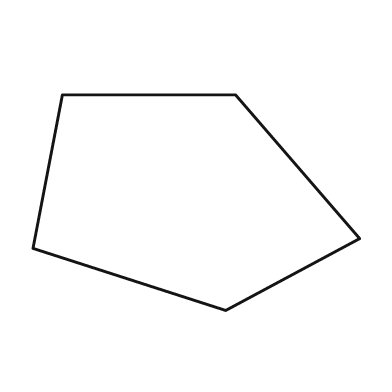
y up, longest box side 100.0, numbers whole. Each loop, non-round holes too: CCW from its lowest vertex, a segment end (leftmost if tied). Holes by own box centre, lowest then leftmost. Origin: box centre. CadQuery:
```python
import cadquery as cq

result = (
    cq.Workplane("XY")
    .moveTo(9.0, -33.0)
    .lineTo(50.0, -11.0)
    .lineTo(12.0, 33.0)
    .lineTo(-41.0, 33.0)
    .lineTo(-50.0, -14.0)
    .close()
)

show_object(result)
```